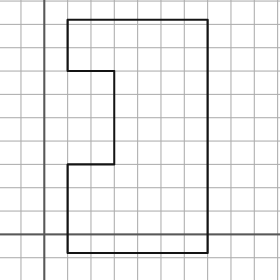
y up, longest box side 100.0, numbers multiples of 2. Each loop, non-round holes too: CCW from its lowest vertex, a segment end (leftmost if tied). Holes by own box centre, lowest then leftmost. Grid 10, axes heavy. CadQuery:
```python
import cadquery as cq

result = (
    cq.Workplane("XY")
    .moveTo(10.0, -8.0)
    .lineTo(70.0, -8.0)
    .lineTo(70.0, 92.0)
    .lineTo(10.0, 92.0)
    .lineTo(10.0, 70.0)
    .lineTo(30.0, 70.0)
    .lineTo(30.0, 30.0)
    .lineTo(10.0, 30.0)
    .close()
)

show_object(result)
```